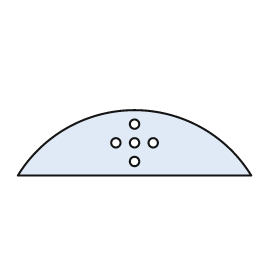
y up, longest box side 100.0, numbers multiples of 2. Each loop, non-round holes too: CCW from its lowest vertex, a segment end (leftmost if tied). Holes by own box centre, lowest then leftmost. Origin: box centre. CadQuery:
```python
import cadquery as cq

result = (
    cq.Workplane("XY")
    .moveTo(-50.0, -14.0)
    .lineTo(50.0, -14.0)
    .threePointArc((0.0, 14.0), (-50.0, -14.0))
    .close()
    .moveTo(0.0, -8.0)
    .circle(2.0)
    .moveTo(-8.0, 0.0)
    .circle(2.0)
    .moveTo(0.0, 0.0)
    .circle(2.0)
    .moveTo(8.0, 0.0)
    .circle(2.0)
    .moveTo(0.0, 8.0)
    .circle(2.0)
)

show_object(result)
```